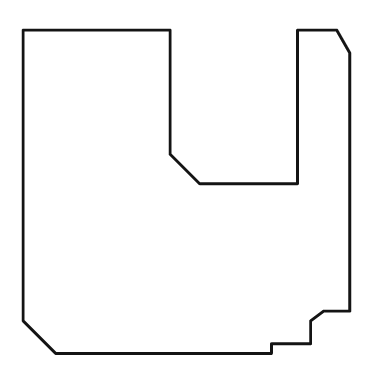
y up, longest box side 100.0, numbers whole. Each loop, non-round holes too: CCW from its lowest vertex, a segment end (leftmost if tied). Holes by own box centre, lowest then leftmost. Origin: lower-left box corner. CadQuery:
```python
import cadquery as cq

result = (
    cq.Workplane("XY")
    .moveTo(10.0, 0.0)
    .lineTo(76.0, 0.0)
    .lineTo(76.0, 3.0)
    .lineTo(88.0, 3.0)
    .lineTo(88.0, 10.0)
    .lineTo(92.0, 13.0)
    .lineTo(100.0, 13.0)
    .lineTo(100.0, 92.0)
    .lineTo(96.0, 99.0)
    .lineTo(84.0, 99.0)
    .lineTo(84.0, 52.0)
    .lineTo(54.0, 52.0)
    .lineTo(45.0, 61.0)
    .lineTo(45.0, 99.0)
    .lineTo(0.0, 99.0)
    .lineTo(0.0, 10.0)
    .close()
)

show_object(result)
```